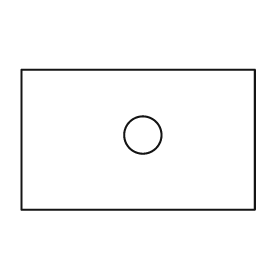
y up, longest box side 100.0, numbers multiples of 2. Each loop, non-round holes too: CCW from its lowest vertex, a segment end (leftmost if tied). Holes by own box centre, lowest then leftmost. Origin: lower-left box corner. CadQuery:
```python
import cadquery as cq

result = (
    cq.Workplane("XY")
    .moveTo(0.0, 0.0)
    .lineTo(100.0, 0.0)
    .lineTo(100.0, 60.0)
    .lineTo(0.0, 60.0)
    .close()
    .moveTo(52.0, 32.0)
    .circle(8.0)
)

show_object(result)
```